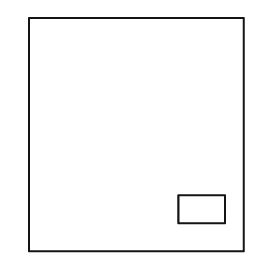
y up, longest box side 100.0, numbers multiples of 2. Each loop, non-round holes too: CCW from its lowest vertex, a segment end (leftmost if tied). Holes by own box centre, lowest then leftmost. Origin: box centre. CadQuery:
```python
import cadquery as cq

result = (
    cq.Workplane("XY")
    .moveTo(-46.0, -50.0)
    .lineTo(46.0, -50.0)
    .lineTo(46.0, 50.0)
    .lineTo(-46.0, 50.0)
    .close()
    .moveTo(18.0, -38.0)
    .lineTo(38.0, -38.0)
    .lineTo(38.0, -26.0)
    .lineTo(18.0, -26.0)
    .close()
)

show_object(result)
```